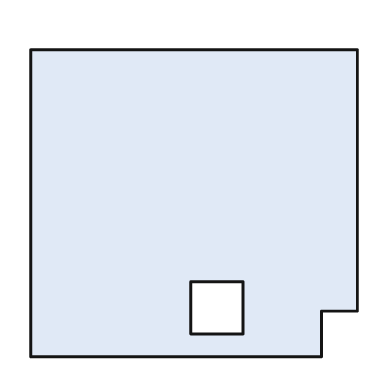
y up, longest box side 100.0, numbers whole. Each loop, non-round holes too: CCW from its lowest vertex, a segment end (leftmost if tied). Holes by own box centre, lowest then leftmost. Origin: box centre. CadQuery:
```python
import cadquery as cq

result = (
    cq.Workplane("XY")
    .moveTo(-50.0, -47.0)
    .lineTo(39.0, -47.0)
    .lineTo(39.0, -33.0)
    .lineTo(50.0, -33.0)
    .lineTo(50.0, 47.0)
    .lineTo(-50.0, 47.0)
    .close()
    .moveTo(-1.0, -40.0)
    .lineTo(15.0, -40.0)
    .lineTo(15.0, -24.0)
    .lineTo(-1.0, -24.0)
    .close()
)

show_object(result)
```